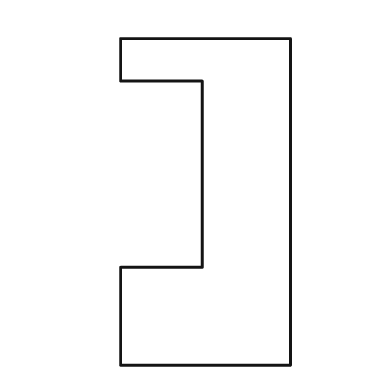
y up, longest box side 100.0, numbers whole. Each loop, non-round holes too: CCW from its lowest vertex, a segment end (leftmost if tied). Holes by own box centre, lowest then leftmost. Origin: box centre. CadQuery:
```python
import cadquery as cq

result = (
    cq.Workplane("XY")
    .moveTo(-26.0, -50.0)
    .lineTo(26.0, -50.0)
    .lineTo(26.0, 50.0)
    .lineTo(-26.0, 50.0)
    .lineTo(-26.0, 37.0)
    .lineTo(-1.0, 37.0)
    .lineTo(-1.0, -20.0)
    .lineTo(-26.0, -20.0)
    .close()
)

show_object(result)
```